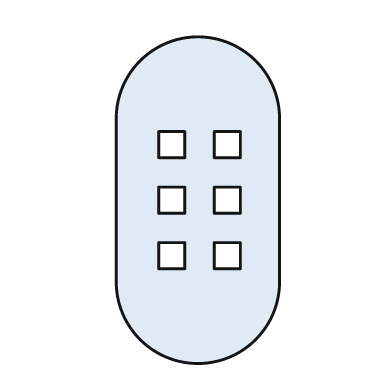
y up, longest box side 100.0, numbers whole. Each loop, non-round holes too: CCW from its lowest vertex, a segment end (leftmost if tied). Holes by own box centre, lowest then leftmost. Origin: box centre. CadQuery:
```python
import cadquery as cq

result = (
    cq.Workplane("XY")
    .moveTo(-25.0, -25.0)
    .threePointArc((0.0, -50.0), (25.0, -25.0))
    .lineTo(25.0, 25.0)
    .threePointArc((0.0, 50.0), (-25.0, 25.0))
    .close()
    .moveTo(-12.0, -21.0)
    .lineTo(-4.0, -21.0)
    .lineTo(-4.0, -13.0)
    .lineTo(-12.0, -13.0)
    .close()
    .moveTo(5.0, -21.0)
    .lineTo(13.0, -21.0)
    .lineTo(13.0, -13.0)
    .lineTo(5.0, -13.0)
    .close()
    .moveTo(-12.0, -4.0)
    .lineTo(-4.0, -4.0)
    .lineTo(-4.0, 4.0)
    .lineTo(-12.0, 4.0)
    .close()
    .moveTo(5.0, -4.0)
    .lineTo(13.0, -4.0)
    .lineTo(13.0, 4.0)
    .lineTo(5.0, 4.0)
    .close()
    .moveTo(-12.0, 13.0)
    .lineTo(-4.0, 13.0)
    .lineTo(-4.0, 21.0)
    .lineTo(-12.0, 21.0)
    .close()
    .moveTo(5.0, 13.0)
    .lineTo(13.0, 13.0)
    .lineTo(13.0, 21.0)
    .lineTo(5.0, 21.0)
    .close()
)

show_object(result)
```